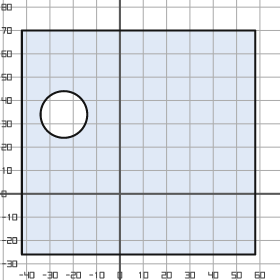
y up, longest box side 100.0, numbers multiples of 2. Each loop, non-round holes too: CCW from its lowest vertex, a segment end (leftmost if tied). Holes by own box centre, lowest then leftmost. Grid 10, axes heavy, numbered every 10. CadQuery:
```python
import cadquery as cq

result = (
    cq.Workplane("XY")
    .moveTo(-42.0, -26.0)
    .lineTo(58.0, -26.0)
    .lineTo(58.0, 70.0)
    .lineTo(-42.0, 70.0)
    .close()
    .moveTo(-24.0, 34.0)
    .circle(10.0)
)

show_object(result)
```